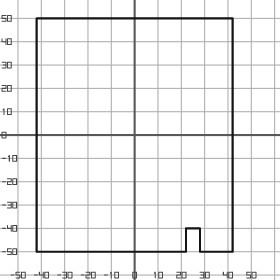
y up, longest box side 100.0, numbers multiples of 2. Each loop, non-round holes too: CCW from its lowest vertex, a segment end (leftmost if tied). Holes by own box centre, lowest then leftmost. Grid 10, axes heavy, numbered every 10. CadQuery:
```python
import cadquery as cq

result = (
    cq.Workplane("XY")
    .moveTo(-42.0, -50.0)
    .lineTo(22.0, -50.0)
    .lineTo(22.0, -40.0)
    .lineTo(28.0, -40.0)
    .lineTo(28.0, -50.0)
    .lineTo(42.0, -50.0)
    .lineTo(42.0, 50.0)
    .lineTo(-42.0, 50.0)
    .close()
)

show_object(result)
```